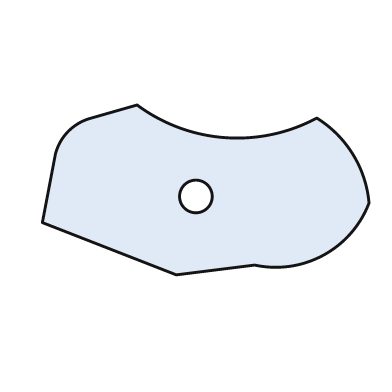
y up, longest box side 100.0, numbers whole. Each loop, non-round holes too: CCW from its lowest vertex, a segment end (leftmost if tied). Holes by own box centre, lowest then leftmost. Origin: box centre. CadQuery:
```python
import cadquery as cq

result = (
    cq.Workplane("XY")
    .moveTo(-9.0, -26.0)
    .lineTo(15.0, -23.0)
    .threePointArc((36.0, -20.0), (50.0, -4.0))
    .threePointArc((45.0, 11.0), (34.0, 22.0))
    .threePointArc((6.0, 16.0), (-21.0, 26.0))
    .lineTo(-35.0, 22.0)
    .threePointArc((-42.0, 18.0), (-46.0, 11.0))
    .lineTo(-50.0, -10.0)
    .close()
    .moveTo(-3.0, -2.0)
    .circle(5.0)
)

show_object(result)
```